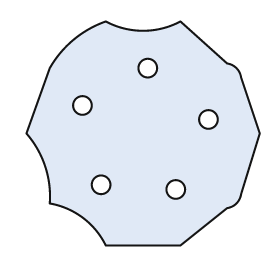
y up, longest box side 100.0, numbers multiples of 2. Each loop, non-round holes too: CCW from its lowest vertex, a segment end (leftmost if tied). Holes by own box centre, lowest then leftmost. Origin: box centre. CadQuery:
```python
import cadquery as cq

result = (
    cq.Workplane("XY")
    .moveTo(-16.0, -48.0)
    .lineTo(16.0, -48.0)
    .lineTo(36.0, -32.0)
    .threePointArc((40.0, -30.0), (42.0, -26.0))
    .lineTo(50.0, 0.0)
    .lineTo(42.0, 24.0)
    .threePointArc((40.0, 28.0), (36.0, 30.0))
    .lineTo(16.0, 48.0)
    .threePointArc((0.0, 44.0), (-16.0, 48.0))
    .threePointArc((-30.0, 40.0), (-40.0, 28.0))
    .lineTo(-50.0, 0.0)
    .threePointArc((-42.0, -14.0), (-40.0, -30.0))
    .threePointArc((-26.0, -36.0), (-16.0, -48.0))
    .close()
    .moveTo(14.0, -24.0)
    .circle(4.0)
    .moveTo(-18.0, -22.0)
    .circle(4.0)
    .moveTo(28.0, 6.0)
    .circle(4.0)
    .moveTo(-26.0, 12.0)
    .circle(4.0)
    .moveTo(2.0, 28.0)
    .circle(4.0)
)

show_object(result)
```